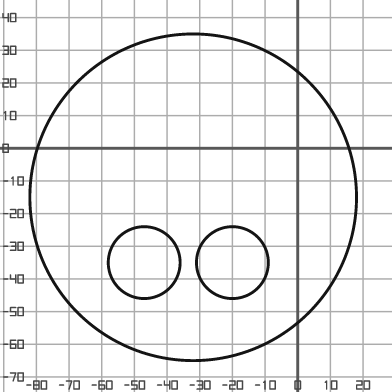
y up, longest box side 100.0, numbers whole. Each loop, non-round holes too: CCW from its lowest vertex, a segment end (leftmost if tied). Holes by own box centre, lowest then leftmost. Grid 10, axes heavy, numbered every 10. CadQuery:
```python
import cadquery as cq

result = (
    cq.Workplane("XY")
    .moveTo(-32.0, -15.0)
    .circle(50.0)
    .moveTo(-47.0, -35.0)
    .circle(11.0)
    .moveTo(-20.0, -35.0)
    .circle(11.0)
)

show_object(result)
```